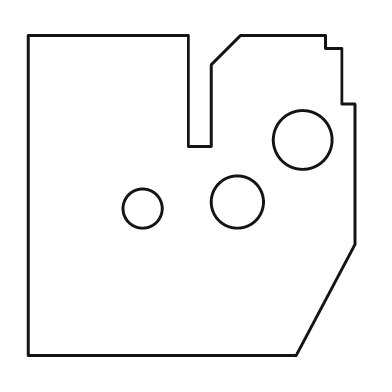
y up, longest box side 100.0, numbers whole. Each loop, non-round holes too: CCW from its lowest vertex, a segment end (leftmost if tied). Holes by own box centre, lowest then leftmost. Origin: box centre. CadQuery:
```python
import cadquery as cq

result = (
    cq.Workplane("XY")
    .moveTo(-50.0, -49.0)
    .lineTo(32.0, -49.0)
    .lineTo(50.0, -15.0)
    .lineTo(50.0, 28.0)
    .lineTo(46.0, 28.0)
    .lineTo(46.0, 45.0)
    .lineTo(41.0, 45.0)
    .lineTo(41.0, 49.0)
    .lineTo(15.0, 49.0)
    .lineTo(6.0, 40.0)
    .lineTo(6.0, 15.0)
    .lineTo(-1.0, 15.0)
    .lineTo(-1.0, 49.0)
    .lineTo(-50.0, 49.0)
    .close()
    .moveTo(-15.0, -4.0)
    .circle(6.0)
    .moveTo(14.0, -2.0)
    .circle(8.0)
    .moveTo(34.0, 17.0)
    .circle(9.0)
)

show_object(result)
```